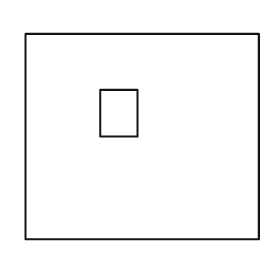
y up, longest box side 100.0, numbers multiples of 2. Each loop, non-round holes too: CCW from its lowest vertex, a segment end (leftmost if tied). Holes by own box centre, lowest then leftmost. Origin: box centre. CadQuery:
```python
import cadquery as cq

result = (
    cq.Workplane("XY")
    .moveTo(-50.0, -44.0)
    .lineTo(50.0, -44.0)
    .lineTo(50.0, 44.0)
    .lineTo(-50.0, 44.0)
    .close()
    .moveTo(-18.0, 0.0)
    .lineTo(-2.0, 0.0)
    .lineTo(-2.0, 20.0)
    .lineTo(-18.0, 20.0)
    .close()
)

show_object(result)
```